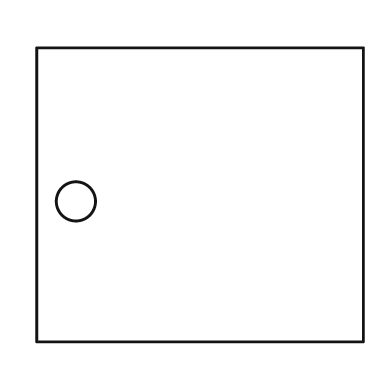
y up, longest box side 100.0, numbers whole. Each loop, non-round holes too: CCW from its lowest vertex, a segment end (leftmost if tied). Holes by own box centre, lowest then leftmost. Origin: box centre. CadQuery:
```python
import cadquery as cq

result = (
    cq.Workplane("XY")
    .moveTo(-50.0, -45.0)
    .lineTo(50.0, -45.0)
    .lineTo(50.0, 45.0)
    .lineTo(-50.0, 45.0)
    .close()
    .moveTo(-38.0, -2.0)
    .circle(6.0)
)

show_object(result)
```